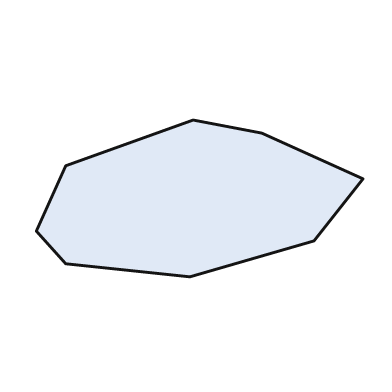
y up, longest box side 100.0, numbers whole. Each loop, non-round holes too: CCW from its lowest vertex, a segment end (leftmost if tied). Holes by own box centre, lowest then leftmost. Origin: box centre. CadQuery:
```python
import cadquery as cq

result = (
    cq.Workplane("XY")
    .moveTo(-3.0, -24.0)
    .lineTo(35.0, -13.0)
    .lineTo(50.0, 6.0)
    .lineTo(19.0, 20.0)
    .lineTo(-2.0, 24.0)
    .lineTo(-41.0, 10.0)
    .lineTo(-50.0, -10.0)
    .lineTo(-41.0, -20.0)
    .close()
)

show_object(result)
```